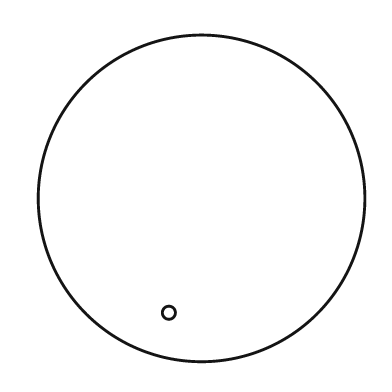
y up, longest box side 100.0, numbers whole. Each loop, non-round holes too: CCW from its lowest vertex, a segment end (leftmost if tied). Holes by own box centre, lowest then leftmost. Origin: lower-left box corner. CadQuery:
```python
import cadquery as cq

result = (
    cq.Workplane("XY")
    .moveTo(50.0, 50.0)
    .circle(50.0)
    .moveTo(40.0, 15.0)
    .circle(2.0)
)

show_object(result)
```